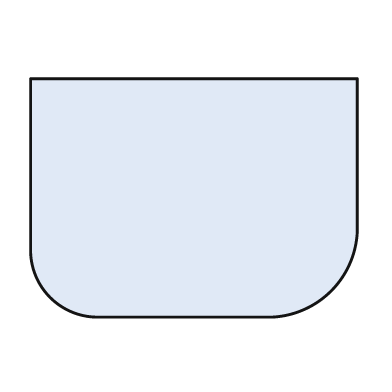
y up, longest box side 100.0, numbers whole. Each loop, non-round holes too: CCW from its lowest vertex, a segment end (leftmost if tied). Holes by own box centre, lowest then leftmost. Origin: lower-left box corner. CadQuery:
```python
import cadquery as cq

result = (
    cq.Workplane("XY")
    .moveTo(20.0, 0.0)
    .lineTo(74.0, 0.0)
    .threePointArc((92.0, 8.0), (100.0, 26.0))
    .lineTo(100.0, 73.0)
    .lineTo(0.0, 73.0)
    .lineTo(0.0, 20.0)
    .threePointArc((6.0, 6.0), (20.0, 0.0))
    .close()
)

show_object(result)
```